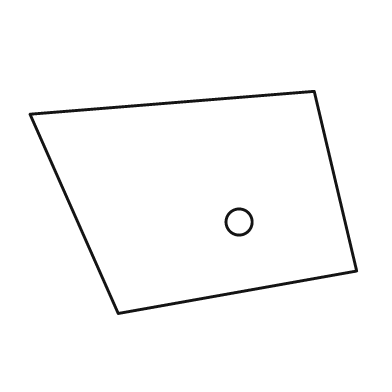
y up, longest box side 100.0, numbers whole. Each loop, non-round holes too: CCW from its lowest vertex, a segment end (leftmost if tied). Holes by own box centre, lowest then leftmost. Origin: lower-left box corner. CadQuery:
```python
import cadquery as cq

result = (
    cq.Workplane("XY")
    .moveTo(27.0, 0.0)
    .lineTo(100.0, 13.0)
    .lineTo(87.0, 68.0)
    .lineTo(0.0, 61.0)
    .close()
    .moveTo(64.0, 28.0)
    .circle(4.0)
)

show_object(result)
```